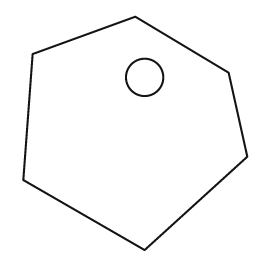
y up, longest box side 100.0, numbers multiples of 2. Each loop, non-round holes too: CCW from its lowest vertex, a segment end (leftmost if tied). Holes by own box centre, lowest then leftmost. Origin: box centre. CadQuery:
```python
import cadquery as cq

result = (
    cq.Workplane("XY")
    .moveTo(4.0, -50.0)
    .lineTo(48.0, -10.0)
    .lineTo(40.0, 26.0)
    .lineTo(0.0, 50.0)
    .lineTo(-44.0, 34.0)
    .lineTo(-48.0, -20.0)
    .close()
    .moveTo(4.0, 24.0)
    .circle(8.0)
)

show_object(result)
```